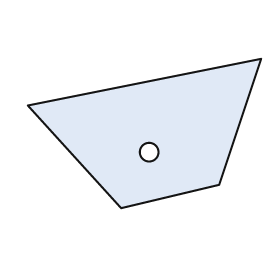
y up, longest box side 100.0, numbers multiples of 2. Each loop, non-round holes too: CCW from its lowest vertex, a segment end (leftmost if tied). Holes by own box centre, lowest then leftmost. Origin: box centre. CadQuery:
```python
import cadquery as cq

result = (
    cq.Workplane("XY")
    .moveTo(-10.0, -32.0)
    .lineTo(32.0, -22.0)
    .lineTo(50.0, 32.0)
    .lineTo(-50.0, 12.0)
    .close()
    .moveTo(2.0, -8.0)
    .circle(4.0)
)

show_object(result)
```